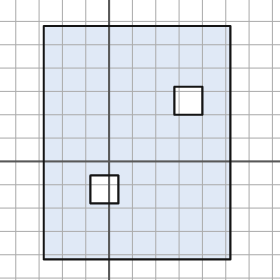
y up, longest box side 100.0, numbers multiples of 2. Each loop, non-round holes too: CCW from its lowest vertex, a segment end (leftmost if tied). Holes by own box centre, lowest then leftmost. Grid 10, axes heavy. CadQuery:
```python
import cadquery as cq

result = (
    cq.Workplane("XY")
    .moveTo(-28.0, -42.0)
    .lineTo(52.0, -42.0)
    .lineTo(52.0, 58.0)
    .lineTo(-28.0, 58.0)
    .close()
    .moveTo(-8.0, -18.0)
    .lineTo(4.0, -18.0)
    .lineTo(4.0, -6.0)
    .lineTo(-8.0, -6.0)
    .close()
    .moveTo(28.0, 20.0)
    .lineTo(40.0, 20.0)
    .lineTo(40.0, 32.0)
    .lineTo(28.0, 32.0)
    .close()
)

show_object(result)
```